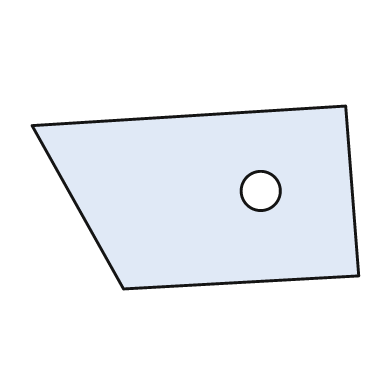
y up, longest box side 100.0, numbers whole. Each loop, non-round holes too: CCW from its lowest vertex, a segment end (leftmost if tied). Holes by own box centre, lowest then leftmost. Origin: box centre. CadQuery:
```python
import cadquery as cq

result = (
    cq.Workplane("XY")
    .moveTo(-22.0, -28.0)
    .lineTo(50.0, -24.0)
    .lineTo(46.0, 28.0)
    .lineTo(-50.0, 22.0)
    .close()
    .moveTo(20.0, 2.0)
    .circle(6.0)
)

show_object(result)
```